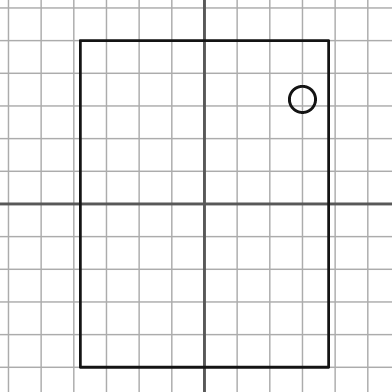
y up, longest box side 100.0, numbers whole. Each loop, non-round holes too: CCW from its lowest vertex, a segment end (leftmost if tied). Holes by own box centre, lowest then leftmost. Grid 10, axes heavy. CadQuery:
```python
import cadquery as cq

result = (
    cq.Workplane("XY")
    .moveTo(-38.0, -50.0)
    .lineTo(38.0, -50.0)
    .lineTo(38.0, 50.0)
    .lineTo(-38.0, 50.0)
    .close()
    .moveTo(30.0, 32.0)
    .circle(4.0)
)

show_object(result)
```